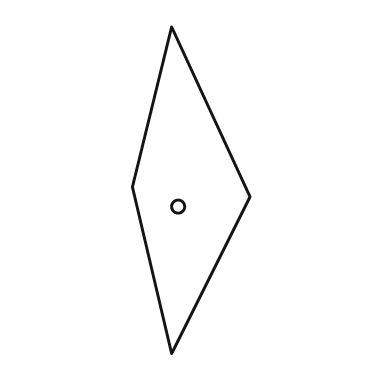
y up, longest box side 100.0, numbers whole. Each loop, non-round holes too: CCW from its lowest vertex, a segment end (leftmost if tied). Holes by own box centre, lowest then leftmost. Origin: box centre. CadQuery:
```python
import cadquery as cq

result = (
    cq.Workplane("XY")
    .moveTo(-6.0, -50.0)
    .lineTo(18.0, -2.0)
    .lineTo(-6.0, 50.0)
    .lineTo(-18.0, 1.0)
    .close()
    .moveTo(-4.0, -5.0)
    .circle(2.0)
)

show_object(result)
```